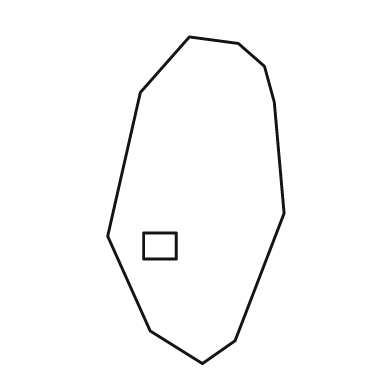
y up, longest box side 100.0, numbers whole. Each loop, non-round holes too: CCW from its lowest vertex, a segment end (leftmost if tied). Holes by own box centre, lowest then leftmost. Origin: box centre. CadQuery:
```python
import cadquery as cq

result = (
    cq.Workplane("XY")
    .moveTo(2.0, -50.0)
    .lineTo(12.0, -43.0)
    .lineTo(27.0, -4.0)
    .lineTo(24.0, 30.0)
    .lineTo(21.0, 41.0)
    .lineTo(13.0, 48.0)
    .lineTo(-2.0, 50.0)
    .lineTo(-17.0, 33.0)
    .lineTo(-27.0, -11.0)
    .lineTo(-14.0, -40.0)
    .close()
    .moveTo(-16.0, -18.0)
    .lineTo(-6.0, -18.0)
    .lineTo(-6.0, -10.0)
    .lineTo(-16.0, -10.0)
    .close()
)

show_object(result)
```